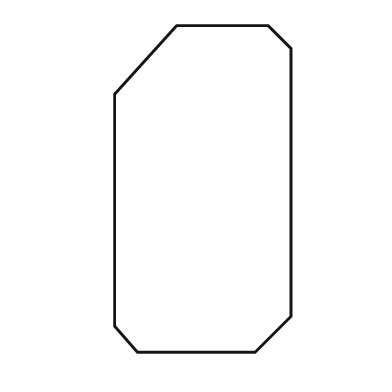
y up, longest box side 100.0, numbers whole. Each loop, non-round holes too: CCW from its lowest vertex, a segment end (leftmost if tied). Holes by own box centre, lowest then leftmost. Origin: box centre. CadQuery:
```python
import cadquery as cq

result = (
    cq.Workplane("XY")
    .moveTo(-20.0, -50.0)
    .lineTo(16.0, -50.0)
    .lineTo(27.0, -39.0)
    .lineTo(27.0, 43.0)
    .lineTo(20.0, 50.0)
    .lineTo(-8.0, 50.0)
    .lineTo(-27.0, 29.0)
    .lineTo(-27.0, -42.0)
    .close()
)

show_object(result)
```